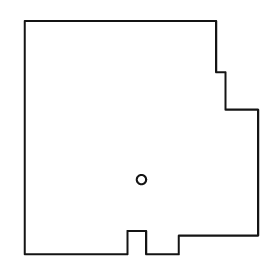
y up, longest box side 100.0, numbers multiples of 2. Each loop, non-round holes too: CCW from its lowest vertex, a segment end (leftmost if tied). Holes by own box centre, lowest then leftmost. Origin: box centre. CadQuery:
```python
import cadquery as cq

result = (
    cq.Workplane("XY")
    .moveTo(-50.0, -50.0)
    .lineTo(-6.0, -50.0)
    .lineTo(-6.0, -40.0)
    .lineTo(2.0, -40.0)
    .lineTo(2.0, -50.0)
    .lineTo(16.0, -50.0)
    .lineTo(16.0, -42.0)
    .lineTo(50.0, -42.0)
    .lineTo(50.0, 12.0)
    .lineTo(36.0, 12.0)
    .lineTo(36.0, 28.0)
    .lineTo(32.0, 28.0)
    .lineTo(32.0, 50.0)
    .lineTo(-50.0, 50.0)
    .close()
    .moveTo(0.0, -18.0)
    .circle(2.0)
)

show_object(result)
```